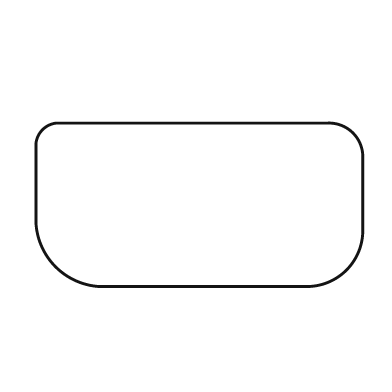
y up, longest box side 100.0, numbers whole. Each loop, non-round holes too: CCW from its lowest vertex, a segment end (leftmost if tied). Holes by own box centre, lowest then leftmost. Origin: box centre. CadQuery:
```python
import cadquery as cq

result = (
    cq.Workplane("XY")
    .moveTo(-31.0, -25.0)
    .lineTo(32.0, -25.0)
    .threePointArc((45.0, -20.0), (50.0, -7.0))
    .lineTo(50.0, 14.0)
    .threePointArc((47.0, 22.0), (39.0, 25.0))
    .lineTo(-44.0, 25.0)
    .threePointArc((-48.0, 23.0), (-50.0, 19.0))
    .lineTo(-50.0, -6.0)
    .threePointArc((-44.0, -19.0), (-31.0, -25.0))
    .close()
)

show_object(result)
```